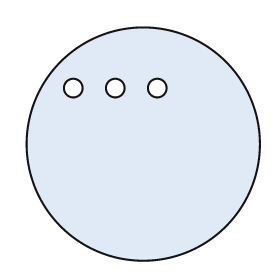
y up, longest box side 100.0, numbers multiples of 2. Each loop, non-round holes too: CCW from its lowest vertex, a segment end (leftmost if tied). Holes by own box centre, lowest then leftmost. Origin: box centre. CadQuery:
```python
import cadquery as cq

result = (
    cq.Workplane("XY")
    .moveTo(0.0, 0.0)
    .circle(50.0)
    .moveTo(-30.0, 24.0)
    .circle(4.0)
    .moveTo(-12.0, 24.0)
    .circle(4.0)
    .moveTo(6.0, 24.0)
    .circle(4.0)
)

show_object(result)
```